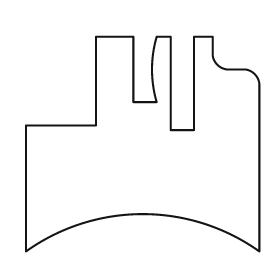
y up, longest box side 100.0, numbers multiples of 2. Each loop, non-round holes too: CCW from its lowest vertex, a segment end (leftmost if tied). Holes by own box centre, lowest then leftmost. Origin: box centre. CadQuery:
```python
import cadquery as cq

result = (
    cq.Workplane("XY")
    .moveTo(-50.0, -46.0)
    .threePointArc((0.0, -30.0), (50.0, -46.0))
    .lineTo(50.0, 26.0)
    .threePointArc((48.0, 30.0), (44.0, 32.0))
    .lineTo(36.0, 32.0)
    .threePointArc((32.0, 34.0), (30.0, 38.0))
    .lineTo(30.0, 46.0)
    .lineTo(22.0, 46.0)
    .lineTo(22.0, 6.0)
    .lineTo(12.0, 6.0)
    .lineTo(12.0, 46.0)
    .lineTo(6.0, 46.0)
    .threePointArc((4.0, 32.0), (6.0, 18.0))
    .lineTo(-4.0, 18.0)
    .lineTo(-4.0, 46.0)
    .lineTo(-20.0, 46.0)
    .lineTo(-20.0, 8.0)
    .lineTo(-50.0, 8.0)
    .close()
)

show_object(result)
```